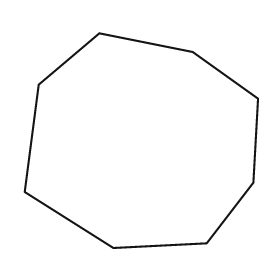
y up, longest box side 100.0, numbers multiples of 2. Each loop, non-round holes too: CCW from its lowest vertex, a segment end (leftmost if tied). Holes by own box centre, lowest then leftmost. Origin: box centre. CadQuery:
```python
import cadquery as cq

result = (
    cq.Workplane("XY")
    .moveTo(-12.0, -46.0)
    .lineTo(28.0, -44.0)
    .lineTo(48.0, -18.0)
    .lineTo(50.0, 18.0)
    .lineTo(22.0, 38.0)
    .lineTo(-18.0, 46.0)
    .lineTo(-44.0, 24.0)
    .lineTo(-50.0, -22.0)
    .close()
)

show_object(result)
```